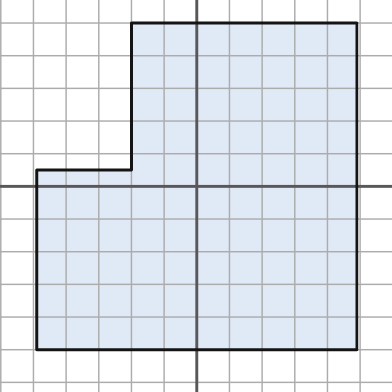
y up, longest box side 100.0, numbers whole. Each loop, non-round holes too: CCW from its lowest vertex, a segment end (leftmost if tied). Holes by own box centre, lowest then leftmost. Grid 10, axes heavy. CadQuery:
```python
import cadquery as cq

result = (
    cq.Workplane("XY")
    .moveTo(-49.0, -50.0)
    .lineTo(49.0, -50.0)
    .lineTo(49.0, 50.0)
    .lineTo(-20.0, 50.0)
    .lineTo(-20.0, 5.0)
    .lineTo(-49.0, 5.0)
    .close()
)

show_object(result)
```